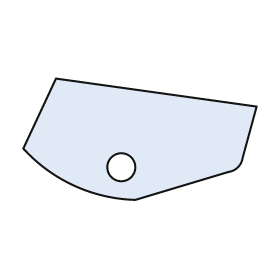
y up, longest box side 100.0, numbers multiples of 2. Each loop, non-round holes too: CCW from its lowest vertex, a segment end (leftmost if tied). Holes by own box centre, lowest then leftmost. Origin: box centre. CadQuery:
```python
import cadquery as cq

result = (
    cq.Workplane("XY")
    .moveTo(-2.0, -26.0)
    .lineTo(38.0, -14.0)
    .threePointArc((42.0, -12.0), (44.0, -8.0))
    .lineTo(50.0, 14.0)
    .lineTo(-36.0, 26.0)
    .lineTo(-50.0, -4.0)
    .threePointArc((-28.0, -20.0), (-2.0, -26.0))
    .close()
    .moveTo(-8.0, -12.0)
    .circle(6.0)
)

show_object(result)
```